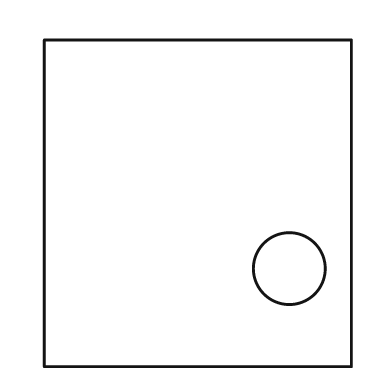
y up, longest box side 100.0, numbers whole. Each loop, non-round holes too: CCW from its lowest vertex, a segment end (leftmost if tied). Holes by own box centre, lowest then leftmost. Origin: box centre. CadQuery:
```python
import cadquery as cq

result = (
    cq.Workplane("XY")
    .moveTo(-47.0, -50.0)
    .lineTo(47.0, -50.0)
    .lineTo(47.0, 50.0)
    .lineTo(-47.0, 50.0)
    .close()
    .moveTo(28.0, -20.0)
    .circle(11.0)
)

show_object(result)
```